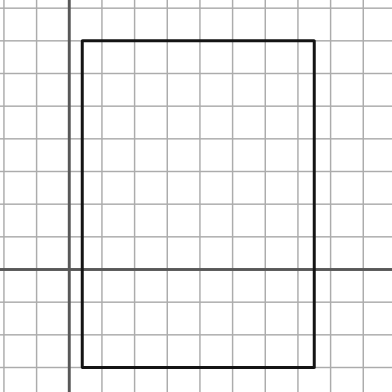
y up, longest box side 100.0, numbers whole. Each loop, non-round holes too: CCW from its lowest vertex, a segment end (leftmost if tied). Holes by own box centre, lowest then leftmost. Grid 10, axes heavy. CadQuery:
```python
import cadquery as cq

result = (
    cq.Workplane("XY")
    .moveTo(4.0, -30.0)
    .lineTo(75.0, -30.0)
    .lineTo(75.0, 70.0)
    .lineTo(4.0, 70.0)
    .close()
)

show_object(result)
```